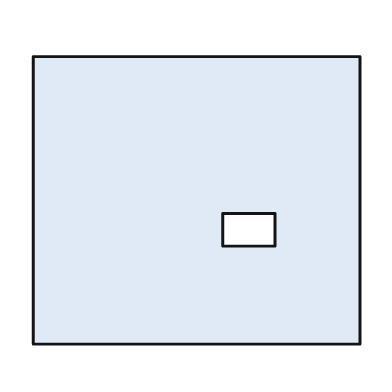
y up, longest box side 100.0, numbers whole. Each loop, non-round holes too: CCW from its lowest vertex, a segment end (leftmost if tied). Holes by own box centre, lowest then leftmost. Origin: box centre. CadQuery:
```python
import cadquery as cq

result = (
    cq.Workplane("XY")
    .moveTo(-50.0, -44.0)
    .lineTo(50.0, -44.0)
    .lineTo(50.0, 44.0)
    .lineTo(-50.0, 44.0)
    .close()
    .moveTo(8.0, -14.0)
    .lineTo(24.0, -14.0)
    .lineTo(24.0, -4.0)
    .lineTo(8.0, -4.0)
    .close()
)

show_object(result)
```